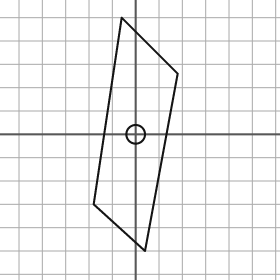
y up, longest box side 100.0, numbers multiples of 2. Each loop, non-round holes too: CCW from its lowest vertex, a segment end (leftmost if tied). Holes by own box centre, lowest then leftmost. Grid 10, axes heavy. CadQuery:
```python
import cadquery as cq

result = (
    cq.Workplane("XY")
    .moveTo(4.0, -50.0)
    .lineTo(18.0, 26.0)
    .lineTo(-6.0, 50.0)
    .lineTo(-18.0, -30.0)
    .close()
    .moveTo(0.0, 0.0)
    .circle(4.0)
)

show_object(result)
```